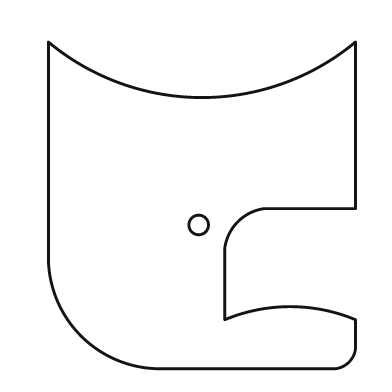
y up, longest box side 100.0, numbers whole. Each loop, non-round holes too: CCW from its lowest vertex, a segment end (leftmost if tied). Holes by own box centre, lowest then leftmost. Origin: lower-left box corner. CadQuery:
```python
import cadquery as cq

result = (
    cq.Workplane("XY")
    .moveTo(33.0, 0.0)
    .lineTo(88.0, 0.0)
    .threePointArc((92.0, 2.0), (94.0, 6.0))
    .lineTo(94.0, 15.0)
    .threePointArc((74.0, 19.0), (54.0, 15.0))
    .lineTo(54.0, 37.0)
    .threePointArc((58.0, 45.0), (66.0, 49.0))
    .lineTo(94.0, 49.0)
    .lineTo(94.0, 100.0)
    .threePointArc((47.0, 83.0), (0.0, 100.0))
    .lineTo(0.0, 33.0)
    .threePointArc((10.0, 10.0), (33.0, 0.0))
    .close()
    .moveTo(46.0, 44.0)
    .circle(3.0)
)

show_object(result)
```